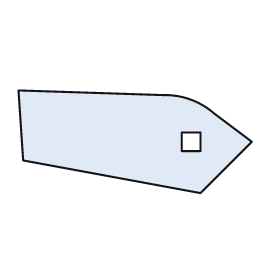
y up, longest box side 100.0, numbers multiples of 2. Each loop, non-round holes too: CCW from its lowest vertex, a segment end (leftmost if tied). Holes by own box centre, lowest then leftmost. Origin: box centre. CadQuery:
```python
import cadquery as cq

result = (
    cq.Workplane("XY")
    .moveTo(28.0, -22.0)
    .lineTo(50.0, 0.0)
    .lineTo(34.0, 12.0)
    .threePointArc((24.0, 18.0), (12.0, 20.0))
    .lineTo(-50.0, 22.0)
    .lineTo(-48.0, -8.0)
    .close()
    .moveTo(20.0, -4.0)
    .lineTo(28.0, -4.0)
    .lineTo(28.0, 4.0)
    .lineTo(20.0, 4.0)
    .close()
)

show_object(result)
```